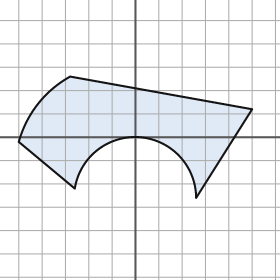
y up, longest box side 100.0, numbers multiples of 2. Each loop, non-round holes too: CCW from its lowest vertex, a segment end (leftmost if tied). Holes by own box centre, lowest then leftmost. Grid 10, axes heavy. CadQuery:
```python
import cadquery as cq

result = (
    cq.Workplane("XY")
    .moveTo(26.0, -26.0)
    .lineTo(50.0, 12.0)
    .lineTo(-28.0, 26.0)
    .threePointArc((-42.0, 14.0), (-50.0, -2.0))
    .lineTo(-26.0, -22.0)
    .threePointArc((2.0, 0.0), (26.0, -26.0))
    .close()
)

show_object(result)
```